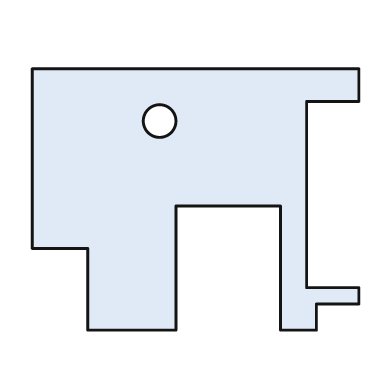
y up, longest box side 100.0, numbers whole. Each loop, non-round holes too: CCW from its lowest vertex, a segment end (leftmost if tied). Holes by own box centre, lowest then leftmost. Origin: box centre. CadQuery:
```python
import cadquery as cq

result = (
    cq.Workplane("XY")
    .moveTo(-33.0, -40.0)
    .lineTo(-6.0, -40.0)
    .lineTo(-6.0, -2.0)
    .lineTo(26.0, -2.0)
    .lineTo(26.0, -40.0)
    .lineTo(37.0, -40.0)
    .lineTo(37.0, -32.0)
    .lineTo(50.0, -32.0)
    .lineTo(50.0, -27.0)
    .lineTo(34.0, -27.0)
    .lineTo(34.0, 30.0)
    .lineTo(50.0, 30.0)
    .lineTo(50.0, 40.0)
    .lineTo(-50.0, 40.0)
    .lineTo(-50.0, -15.0)
    .lineTo(-33.0, -15.0)
    .close()
    .moveTo(-11.0, 24.0)
    .circle(5.0)
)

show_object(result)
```